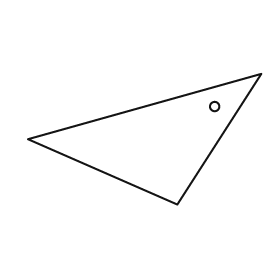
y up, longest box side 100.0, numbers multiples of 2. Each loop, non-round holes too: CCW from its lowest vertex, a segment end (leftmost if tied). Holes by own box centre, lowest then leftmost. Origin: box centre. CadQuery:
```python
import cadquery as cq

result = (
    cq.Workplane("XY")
    .moveTo(14.0, -28.0)
    .lineTo(50.0, 28.0)
    .lineTo(-50.0, 0.0)
    .close()
    .moveTo(30.0, 14.0)
    .circle(2.0)
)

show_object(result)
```